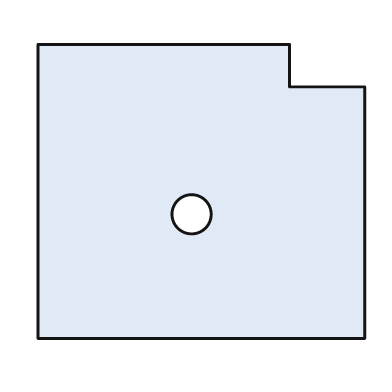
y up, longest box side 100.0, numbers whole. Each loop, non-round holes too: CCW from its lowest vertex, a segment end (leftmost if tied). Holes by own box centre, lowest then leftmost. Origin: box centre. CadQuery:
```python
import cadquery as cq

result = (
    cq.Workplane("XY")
    .moveTo(-50.0, -45.0)
    .lineTo(50.0, -45.0)
    .lineTo(50.0, 32.0)
    .lineTo(27.0, 32.0)
    .lineTo(27.0, 45.0)
    .lineTo(-50.0, 45.0)
    .close()
    .moveTo(-3.0, -7.0)
    .circle(6.0)
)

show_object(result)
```